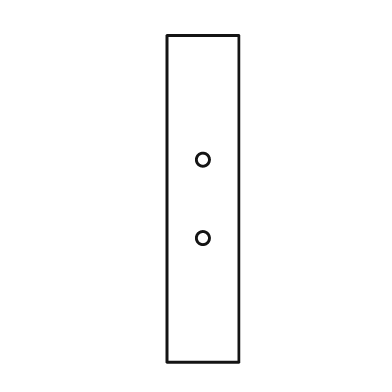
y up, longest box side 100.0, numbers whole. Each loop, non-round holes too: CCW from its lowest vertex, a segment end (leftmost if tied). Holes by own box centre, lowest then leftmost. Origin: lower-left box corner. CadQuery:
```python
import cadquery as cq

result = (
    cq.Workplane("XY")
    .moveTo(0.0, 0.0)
    .lineTo(22.0, 0.0)
    .lineTo(22.0, 100.0)
    .lineTo(0.0, 100.0)
    .close()
    .moveTo(11.0, 38.0)
    .circle(2.0)
    .moveTo(11.0, 62.0)
    .circle(2.0)
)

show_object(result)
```